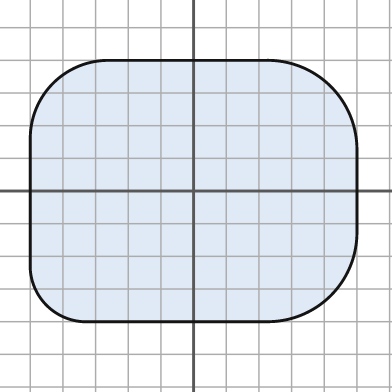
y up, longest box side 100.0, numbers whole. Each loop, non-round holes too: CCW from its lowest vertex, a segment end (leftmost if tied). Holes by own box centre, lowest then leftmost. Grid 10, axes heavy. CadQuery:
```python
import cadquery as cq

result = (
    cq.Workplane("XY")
    .moveTo(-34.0, -40.0)
    .lineTo(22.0, -40.0)
    .threePointArc((42.0, -32.0), (50.0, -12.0))
    .lineTo(50.0, 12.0)
    .threePointArc((42.0, 32.0), (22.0, 40.0))
    .lineTo(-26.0, 40.0)
    .threePointArc((-43.0, 33.0), (-50.0, 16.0))
    .lineTo(-50.0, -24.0)
    .threePointArc((-45.0, -35.0), (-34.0, -40.0))
    .close()
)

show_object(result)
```